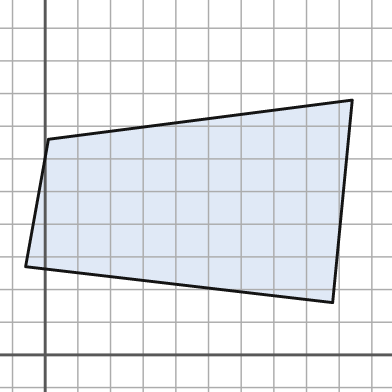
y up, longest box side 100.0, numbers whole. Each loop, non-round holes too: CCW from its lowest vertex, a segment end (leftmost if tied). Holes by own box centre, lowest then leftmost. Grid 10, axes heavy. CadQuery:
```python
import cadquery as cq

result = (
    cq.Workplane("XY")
    .moveTo(88.0, 16.0)
    .lineTo(94.0, 78.0)
    .lineTo(1.0, 66.0)
    .lineTo(-6.0, 27.0)
    .close()
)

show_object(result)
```